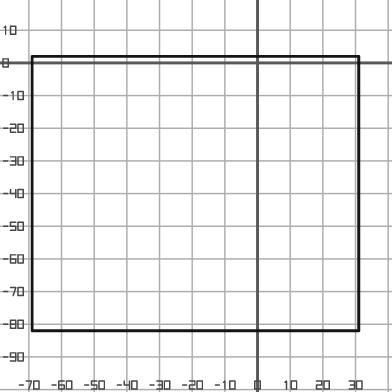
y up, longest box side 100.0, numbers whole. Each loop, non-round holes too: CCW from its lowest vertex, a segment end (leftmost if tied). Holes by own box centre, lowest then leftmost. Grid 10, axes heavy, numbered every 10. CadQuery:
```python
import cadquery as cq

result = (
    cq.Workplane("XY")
    .moveTo(-69.0, -82.0)
    .lineTo(31.0, -82.0)
    .lineTo(31.0, 2.0)
    .lineTo(-69.0, 2.0)
    .close()
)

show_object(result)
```